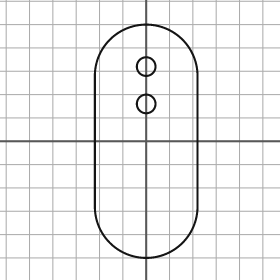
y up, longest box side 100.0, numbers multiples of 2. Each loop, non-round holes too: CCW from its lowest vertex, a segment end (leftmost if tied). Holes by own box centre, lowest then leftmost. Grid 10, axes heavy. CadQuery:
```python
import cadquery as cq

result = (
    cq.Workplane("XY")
    .moveTo(-22.0, -28.0)
    .threePointArc((0.0, -50.0), (22.0, -28.0))
    .lineTo(22.0, 28.0)
    .threePointArc((0.0, 50.0), (-22.0, 28.0))
    .close()
    .moveTo(0.0, 16.0)
    .circle(4.0)
    .moveTo(0.0, 32.0)
    .circle(4.0)
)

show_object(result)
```